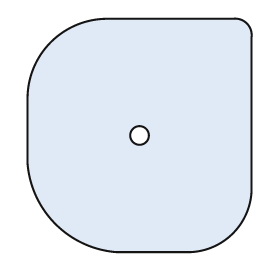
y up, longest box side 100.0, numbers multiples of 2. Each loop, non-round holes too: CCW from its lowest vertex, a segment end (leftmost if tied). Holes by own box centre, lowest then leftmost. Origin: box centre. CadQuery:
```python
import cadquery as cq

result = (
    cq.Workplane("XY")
    .moveTo(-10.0, -50.0)
    .lineTo(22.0, -50.0)
    .threePointArc((40.0, -42.0), (48.0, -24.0))
    .lineTo(48.0, 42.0)
    .threePointArc((46.0, 48.0), (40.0, 50.0))
    .lineTo(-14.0, 50.0)
    .threePointArc((-38.0, 40.0), (-48.0, 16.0))
    .lineTo(-48.0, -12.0)
    .threePointArc((-36.0, -38.0), (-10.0, -50.0))
    .close()
    .moveTo(0.0, 0.0)
    .circle(4.0)
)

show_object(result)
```